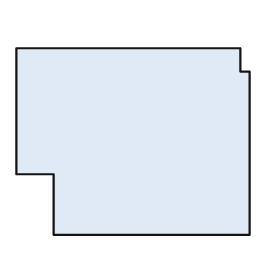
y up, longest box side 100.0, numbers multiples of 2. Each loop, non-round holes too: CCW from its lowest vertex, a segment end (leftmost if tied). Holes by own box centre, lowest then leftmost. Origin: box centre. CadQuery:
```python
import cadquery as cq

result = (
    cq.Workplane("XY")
    .moveTo(-34.0, -40.0)
    .lineTo(50.0, -40.0)
    .lineTo(50.0, 30.0)
    .lineTo(46.0, 30.0)
    .lineTo(46.0, 40.0)
    .lineTo(-50.0, 40.0)
    .lineTo(-50.0, -14.0)
    .lineTo(-34.0, -14.0)
    .close()
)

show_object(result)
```